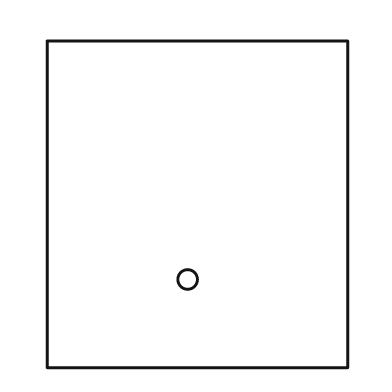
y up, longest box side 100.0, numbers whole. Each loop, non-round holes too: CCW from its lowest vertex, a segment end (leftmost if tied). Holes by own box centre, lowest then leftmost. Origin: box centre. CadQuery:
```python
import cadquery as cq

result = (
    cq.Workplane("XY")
    .moveTo(-46.0, -50.0)
    .lineTo(46.0, -50.0)
    .lineTo(46.0, 50.0)
    .lineTo(-46.0, 50.0)
    .close()
    .moveTo(-3.0, -23.0)
    .circle(3.0)
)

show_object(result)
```